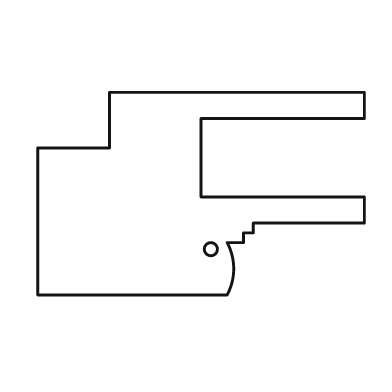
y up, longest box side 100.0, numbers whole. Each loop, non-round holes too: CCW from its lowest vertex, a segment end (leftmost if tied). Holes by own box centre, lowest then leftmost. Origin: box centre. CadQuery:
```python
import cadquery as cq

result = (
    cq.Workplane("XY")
    .moveTo(-50.0, -31.0)
    .lineTo(8.0, -31.0)
    .threePointArc((10.0, -23.0), (8.0, -15.0))
    .lineTo(13.0, -15.0)
    .lineTo(13.0, -12.0)
    .lineTo(16.0, -12.0)
    .lineTo(16.0, -9.0)
    .lineTo(50.0, -9.0)
    .lineTo(50.0, -1.0)
    .lineTo(0.0, -1.0)
    .lineTo(0.0, 23.0)
    .lineTo(50.0, 23.0)
    .lineTo(50.0, 31.0)
    .lineTo(-28.0, 31.0)
    .lineTo(-28.0, 14.0)
    .lineTo(-50.0, 14.0)
    .close()
    .moveTo(3.0, -17.0)
    .circle(2.0)
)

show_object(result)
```